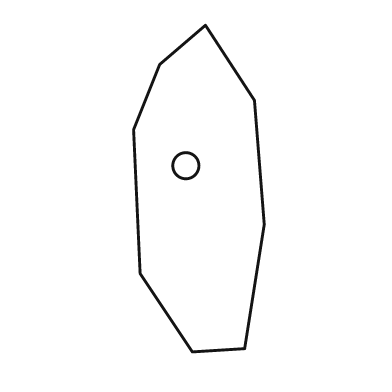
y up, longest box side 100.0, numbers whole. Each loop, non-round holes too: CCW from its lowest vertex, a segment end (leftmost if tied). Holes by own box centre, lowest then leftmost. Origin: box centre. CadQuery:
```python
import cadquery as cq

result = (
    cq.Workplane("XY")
    .moveTo(-2.0, -50.0)
    .lineTo(14.0, -49.0)
    .lineTo(20.0, -11.0)
    .lineTo(17.0, 27.0)
    .lineTo(2.0, 50.0)
    .lineTo(-12.0, 38.0)
    .lineTo(-20.0, 18.0)
    .lineTo(-18.0, -26.0)
    .close()
    .moveTo(-4.0, 7.0)
    .circle(4.0)
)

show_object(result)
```